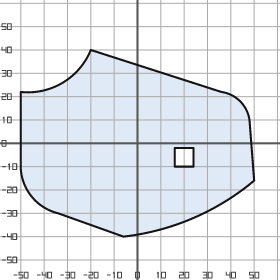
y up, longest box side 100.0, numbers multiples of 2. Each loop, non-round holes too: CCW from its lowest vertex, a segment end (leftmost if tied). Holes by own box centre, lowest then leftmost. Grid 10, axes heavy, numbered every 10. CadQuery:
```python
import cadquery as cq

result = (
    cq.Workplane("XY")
    .moveTo(-6.0, -40.0)
    .threePointArc((24.0, -32.0), (50.0, -16.0))
    .lineTo(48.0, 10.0)
    .threePointArc((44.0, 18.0), (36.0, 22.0))
    .lineTo(-20.0, 40.0)
    .threePointArc((-32.0, 26.0), (-50.0, 22.0))
    .lineTo(-50.0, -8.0)
    .threePointArc((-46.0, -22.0), (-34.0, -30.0))
    .close()
    .moveTo(16.0, -10.0)
    .lineTo(24.0, -10.0)
    .lineTo(24.0, -2.0)
    .lineTo(16.0, -2.0)
    .close()
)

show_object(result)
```